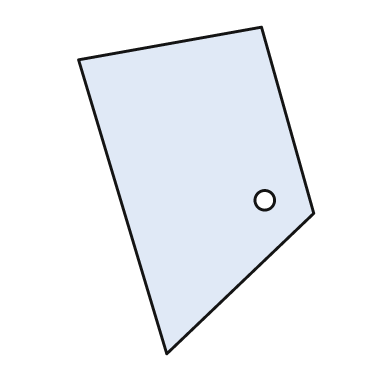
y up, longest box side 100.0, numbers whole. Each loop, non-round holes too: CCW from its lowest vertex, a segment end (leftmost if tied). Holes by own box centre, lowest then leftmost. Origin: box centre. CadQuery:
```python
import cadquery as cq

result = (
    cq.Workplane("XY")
    .moveTo(-9.0, -50.0)
    .lineTo(36.0, -7.0)
    .lineTo(20.0, 50.0)
    .lineTo(-36.0, 40.0)
    .close()
    .moveTo(21.0, -3.0)
    .circle(3.0)
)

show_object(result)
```